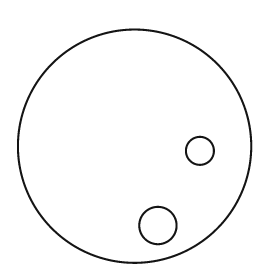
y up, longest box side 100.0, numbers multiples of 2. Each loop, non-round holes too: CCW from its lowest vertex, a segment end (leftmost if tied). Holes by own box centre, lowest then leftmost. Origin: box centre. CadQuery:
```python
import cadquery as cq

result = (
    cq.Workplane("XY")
    .moveTo(0.0, 0.0)
    .circle(50.0)
    .moveTo(10.0, -34.0)
    .circle(8.0)
    .moveTo(28.0, -2.0)
    .circle(6.0)
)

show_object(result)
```